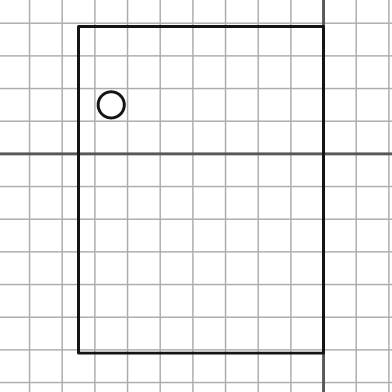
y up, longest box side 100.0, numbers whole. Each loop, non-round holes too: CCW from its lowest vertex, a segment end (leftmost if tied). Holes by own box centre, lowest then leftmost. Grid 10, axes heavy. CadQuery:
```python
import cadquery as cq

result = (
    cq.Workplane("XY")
    .moveTo(-75.0, -61.0)
    .lineTo(0.0, -61.0)
    .lineTo(0.0, 39.0)
    .lineTo(-75.0, 39.0)
    .close()
    .moveTo(-65.0, 15.0)
    .circle(4.0)
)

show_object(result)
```